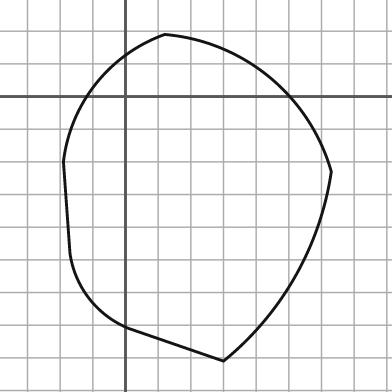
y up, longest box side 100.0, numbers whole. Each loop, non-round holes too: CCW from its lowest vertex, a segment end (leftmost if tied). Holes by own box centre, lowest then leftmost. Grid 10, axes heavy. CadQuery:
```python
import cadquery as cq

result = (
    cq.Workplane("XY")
    .moveTo(30.0, -81.0)
    .threePointArc((52.0, -55.0), (63.0, -23.0))
    .threePointArc((44.0, 6.0), (12.0, 19.0))
    .threePointArc((-9.0, 4.0), (-19.0, -20.0))
    .lineTo(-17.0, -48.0)
    .threePointArc((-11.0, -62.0), (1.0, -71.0))
    .close()
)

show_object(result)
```